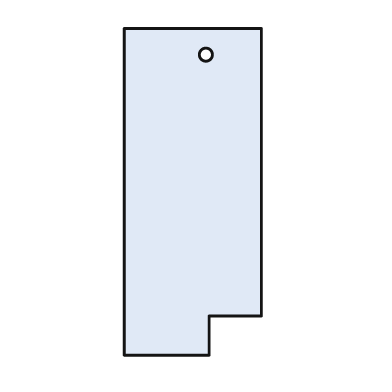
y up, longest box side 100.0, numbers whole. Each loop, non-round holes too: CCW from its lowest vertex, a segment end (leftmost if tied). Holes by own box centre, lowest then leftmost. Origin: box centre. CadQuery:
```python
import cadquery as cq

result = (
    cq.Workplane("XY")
    .moveTo(-21.0, -50.0)
    .lineTo(5.0, -50.0)
    .lineTo(5.0, -38.0)
    .lineTo(21.0, -38.0)
    .lineTo(21.0, 50.0)
    .lineTo(-21.0, 50.0)
    .close()
    .moveTo(4.0, 42.0)
    .circle(2.0)
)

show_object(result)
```